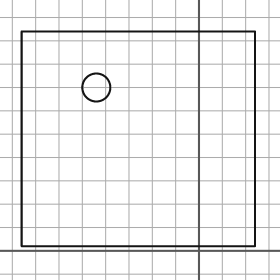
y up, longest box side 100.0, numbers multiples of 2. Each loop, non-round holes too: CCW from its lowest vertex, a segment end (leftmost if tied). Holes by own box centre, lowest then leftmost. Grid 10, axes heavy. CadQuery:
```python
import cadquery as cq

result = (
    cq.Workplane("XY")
    .moveTo(-76.0, 2.0)
    .lineTo(24.0, 2.0)
    .lineTo(24.0, 94.0)
    .lineTo(-76.0, 94.0)
    .close()
    .moveTo(-44.0, 70.0)
    .circle(6.0)
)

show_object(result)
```